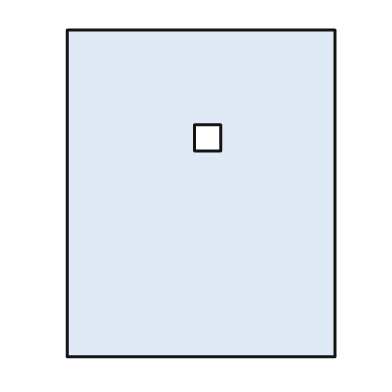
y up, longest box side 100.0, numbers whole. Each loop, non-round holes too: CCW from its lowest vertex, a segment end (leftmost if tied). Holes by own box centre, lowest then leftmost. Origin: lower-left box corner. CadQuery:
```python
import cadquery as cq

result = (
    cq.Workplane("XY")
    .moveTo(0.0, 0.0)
    .lineTo(82.0, 0.0)
    .lineTo(82.0, 100.0)
    .lineTo(0.0, 100.0)
    .close()
    .moveTo(39.0, 63.0)
    .lineTo(47.0, 63.0)
    .lineTo(47.0, 71.0)
    .lineTo(39.0, 71.0)
    .close()
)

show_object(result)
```